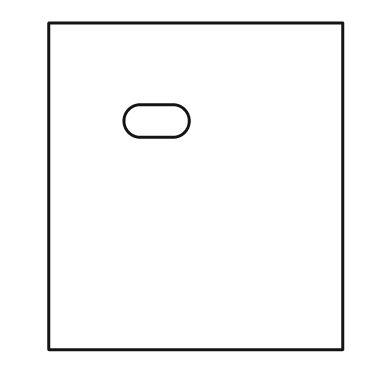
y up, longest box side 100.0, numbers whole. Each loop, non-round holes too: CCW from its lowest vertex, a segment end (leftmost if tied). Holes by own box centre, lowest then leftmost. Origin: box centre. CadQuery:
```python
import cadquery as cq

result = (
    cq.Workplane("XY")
    .moveTo(-45.0, -50.0)
    .lineTo(45.0, -50.0)
    .lineTo(45.0, 50.0)
    .lineTo(-45.0, 50.0)
    .close()
    .moveTo(-17.0, 15.0)
    .lineTo(-7.0, 15.0)
    .threePointArc((-2.0, 20.0), (-7.0, 25.0))
    .lineTo(-17.0, 25.0)
    .threePointArc((-22.0, 20.0), (-17.0, 15.0))
    .close()
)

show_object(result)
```